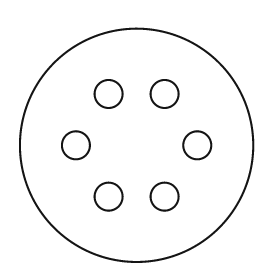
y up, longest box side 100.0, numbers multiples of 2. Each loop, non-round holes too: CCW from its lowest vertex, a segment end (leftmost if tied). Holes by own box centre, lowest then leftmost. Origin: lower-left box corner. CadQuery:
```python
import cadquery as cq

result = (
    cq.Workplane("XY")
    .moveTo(50.0, 50.0)
    .circle(50.0)
    .moveTo(38.0, 28.0)
    .circle(6.0)
    .moveTo(62.0, 28.0)
    .circle(6.0)
    .moveTo(24.0, 50.0)
    .circle(6.0)
    .moveTo(76.0, 50.0)
    .circle(6.0)
    .moveTo(38.0, 72.0)
    .circle(6.0)
    .moveTo(62.0, 72.0)
    .circle(6.0)
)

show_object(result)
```